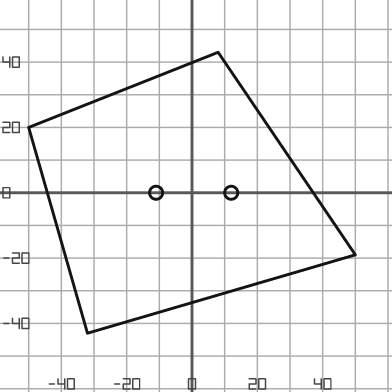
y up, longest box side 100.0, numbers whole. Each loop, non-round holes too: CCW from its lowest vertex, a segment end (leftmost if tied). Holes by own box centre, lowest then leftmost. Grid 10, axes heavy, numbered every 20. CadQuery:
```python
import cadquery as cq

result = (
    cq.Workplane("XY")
    .moveTo(-32.0, -43.0)
    .lineTo(50.0, -19.0)
    .lineTo(8.0, 43.0)
    .lineTo(-50.0, 20.0)
    .close()
    .moveTo(-11.0, 0.0)
    .circle(2.0)
    .moveTo(12.0, 0.0)
    .circle(2.0)
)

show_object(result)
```